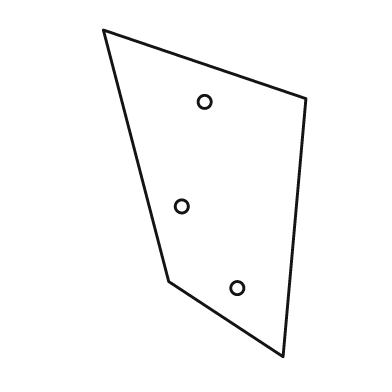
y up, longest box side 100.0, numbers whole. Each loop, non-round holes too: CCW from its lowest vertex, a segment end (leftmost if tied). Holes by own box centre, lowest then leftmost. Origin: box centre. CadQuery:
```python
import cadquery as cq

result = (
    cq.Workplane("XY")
    .moveTo(24.0, -50.0)
    .lineTo(31.0, 29.0)
    .lineTo(-31.0, 50.0)
    .lineTo(-11.0, -27.0)
    .close()
    .moveTo(10.0, -29.0)
    .circle(2.0)
    .moveTo(-7.0, -4.0)
    .circle(2.0)
    .moveTo(0.0, 28.0)
    .circle(2.0)
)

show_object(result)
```